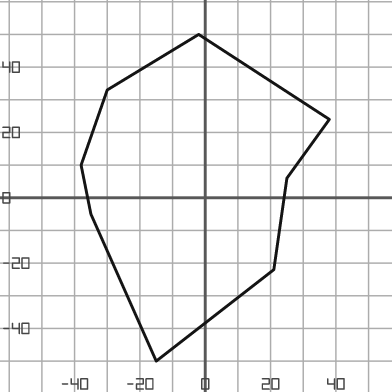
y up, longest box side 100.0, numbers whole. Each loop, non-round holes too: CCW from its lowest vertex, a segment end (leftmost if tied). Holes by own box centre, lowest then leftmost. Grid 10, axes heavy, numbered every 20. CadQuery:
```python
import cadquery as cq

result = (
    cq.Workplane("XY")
    .moveTo(-15.0, -50.0)
    .lineTo(21.0, -22.0)
    .lineTo(25.0, 6.0)
    .lineTo(38.0, 24.0)
    .lineTo(-2.0, 50.0)
    .lineTo(-30.0, 33.0)
    .lineTo(-38.0, 10.0)
    .lineTo(-35.0, -5.0)
    .close()
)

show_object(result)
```